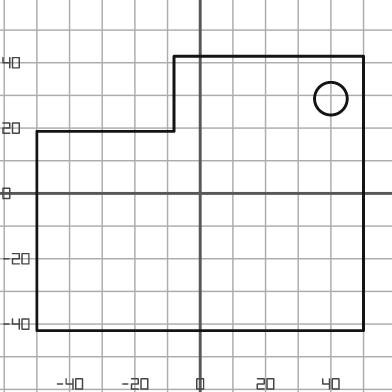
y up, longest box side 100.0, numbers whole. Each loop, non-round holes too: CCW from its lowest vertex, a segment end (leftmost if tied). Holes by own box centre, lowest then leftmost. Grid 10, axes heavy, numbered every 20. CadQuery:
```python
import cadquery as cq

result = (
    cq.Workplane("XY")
    .moveTo(-50.0, -42.0)
    .lineTo(50.0, -42.0)
    .lineTo(50.0, 42.0)
    .lineTo(-8.0, 42.0)
    .lineTo(-8.0, 19.0)
    .lineTo(-50.0, 19.0)
    .close()
    .moveTo(40.0, 29.0)
    .circle(5.0)
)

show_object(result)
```